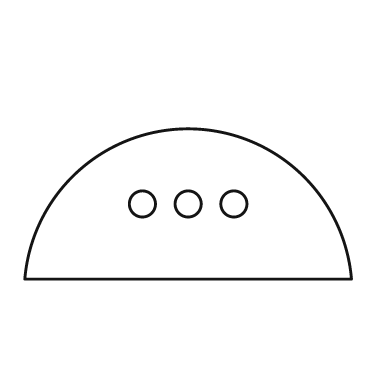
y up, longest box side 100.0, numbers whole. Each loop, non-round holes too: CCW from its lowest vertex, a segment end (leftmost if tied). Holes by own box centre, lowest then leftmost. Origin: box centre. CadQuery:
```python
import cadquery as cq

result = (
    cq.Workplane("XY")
    .moveTo(-50.0, -23.0)
    .lineTo(50.0, -23.0)
    .threePointArc((0.0, 23.0), (-50.0, -23.0))
    .close()
    .moveTo(-14.0, 0.0)
    .circle(4.0)
    .moveTo(0.0, 0.0)
    .circle(4.0)
    .moveTo(14.0, 0.0)
    .circle(4.0)
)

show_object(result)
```